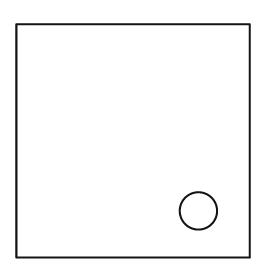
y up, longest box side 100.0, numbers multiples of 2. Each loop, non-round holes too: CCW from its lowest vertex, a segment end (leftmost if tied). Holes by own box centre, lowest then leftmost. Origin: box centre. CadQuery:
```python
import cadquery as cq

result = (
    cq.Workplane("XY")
    .moveTo(-50.0, -50.0)
    .lineTo(50.0, -50.0)
    .lineTo(50.0, 50.0)
    .lineTo(-50.0, 50.0)
    .close()
    .moveTo(28.0, -30.0)
    .circle(8.0)
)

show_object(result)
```